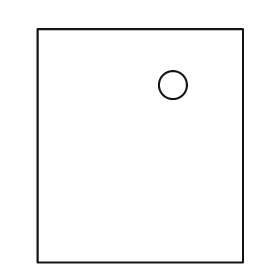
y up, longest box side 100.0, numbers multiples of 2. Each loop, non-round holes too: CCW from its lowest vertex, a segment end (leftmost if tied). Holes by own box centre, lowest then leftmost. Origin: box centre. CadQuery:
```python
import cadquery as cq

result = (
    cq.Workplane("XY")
    .moveTo(-44.0, -50.0)
    .lineTo(44.0, -50.0)
    .lineTo(44.0, 50.0)
    .lineTo(-44.0, 50.0)
    .close()
    .moveTo(14.0, 26.0)
    .circle(6.0)
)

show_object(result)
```